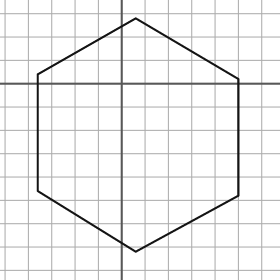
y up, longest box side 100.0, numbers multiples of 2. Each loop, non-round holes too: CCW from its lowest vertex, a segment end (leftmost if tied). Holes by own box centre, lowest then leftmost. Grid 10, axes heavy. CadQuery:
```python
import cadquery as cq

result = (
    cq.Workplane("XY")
    .moveTo(6.0, -72.0)
    .lineTo(50.0, -48.0)
    .lineTo(50.0, 2.0)
    .lineTo(6.0, 28.0)
    .lineTo(-36.0, 4.0)
    .lineTo(-36.0, -46.0)
    .close()
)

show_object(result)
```